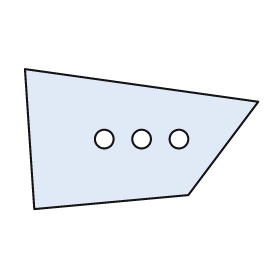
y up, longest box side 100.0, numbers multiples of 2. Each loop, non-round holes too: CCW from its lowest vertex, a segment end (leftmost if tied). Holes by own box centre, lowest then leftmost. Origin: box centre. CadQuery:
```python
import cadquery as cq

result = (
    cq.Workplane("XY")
    .moveTo(-46.0, -30.0)
    .lineTo(20.0, -24.0)
    .lineTo(50.0, 16.0)
    .lineTo(-50.0, 30.0)
    .close()
    .moveTo(-16.0, 0.0)
    .circle(4.0)
    .moveTo(0.0, 0.0)
    .circle(4.0)
    .moveTo(16.0, 0.0)
    .circle(4.0)
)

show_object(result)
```